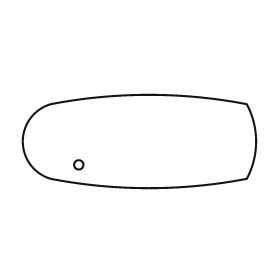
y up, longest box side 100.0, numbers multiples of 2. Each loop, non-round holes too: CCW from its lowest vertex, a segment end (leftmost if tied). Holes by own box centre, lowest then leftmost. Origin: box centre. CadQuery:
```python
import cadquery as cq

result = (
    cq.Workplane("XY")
    .moveTo(-38.0, -16.0)
    .threePointArc((4.0, -20.0), (46.0, -16.0))
    .threePointArc((50.0, 0.0), (46.0, 16.0))
    .threePointArc((4.0, 20.0), (-38.0, 16.0))
    .threePointArc((-50.0, 0.0), (-38.0, -16.0))
    .close()
    .moveTo(-26.0, -10.0)
    .circle(2.0)
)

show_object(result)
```